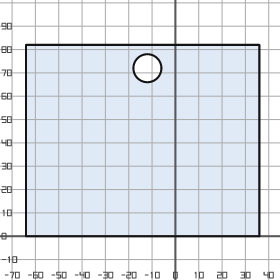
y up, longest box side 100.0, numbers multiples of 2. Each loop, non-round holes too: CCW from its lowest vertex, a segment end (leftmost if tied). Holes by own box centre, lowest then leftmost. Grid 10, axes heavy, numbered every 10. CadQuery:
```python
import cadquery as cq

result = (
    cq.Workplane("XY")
    .moveTo(-64.0, 0.0)
    .lineTo(36.0, 0.0)
    .lineTo(36.0, 82.0)
    .lineTo(-64.0, 82.0)
    .close()
    .moveTo(-12.0, 72.0)
    .circle(6.0)
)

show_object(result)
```